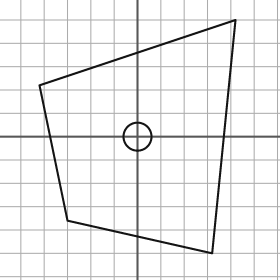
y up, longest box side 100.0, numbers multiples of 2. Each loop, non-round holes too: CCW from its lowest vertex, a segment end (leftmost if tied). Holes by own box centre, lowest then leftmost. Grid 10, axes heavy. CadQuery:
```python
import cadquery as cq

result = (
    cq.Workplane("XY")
    .moveTo(32.0, -50.0)
    .lineTo(42.0, 50.0)
    .lineTo(-42.0, 22.0)
    .lineTo(-30.0, -36.0)
    .close()
    .moveTo(0.0, 0.0)
    .circle(6.0)
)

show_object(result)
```